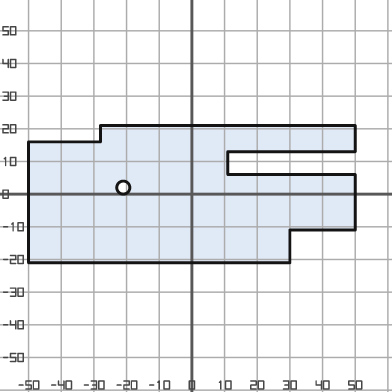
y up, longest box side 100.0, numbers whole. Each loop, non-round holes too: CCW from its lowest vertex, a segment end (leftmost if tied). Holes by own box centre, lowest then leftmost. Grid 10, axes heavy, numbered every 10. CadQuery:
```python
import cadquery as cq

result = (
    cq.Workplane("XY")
    .moveTo(-50.0, -21.0)
    .lineTo(30.0, -21.0)
    .lineTo(30.0, -11.0)
    .lineTo(50.0, -11.0)
    .lineTo(50.0, 6.0)
    .lineTo(11.0, 6.0)
    .lineTo(11.0, 13.0)
    .lineTo(50.0, 13.0)
    .lineTo(50.0, 21.0)
    .lineTo(-28.0, 21.0)
    .lineTo(-28.0, 16.0)
    .lineTo(-50.0, 16.0)
    .close()
    .moveTo(-21.0, 2.0)
    .circle(2.0)
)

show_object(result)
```